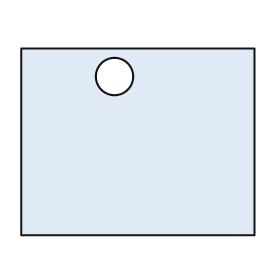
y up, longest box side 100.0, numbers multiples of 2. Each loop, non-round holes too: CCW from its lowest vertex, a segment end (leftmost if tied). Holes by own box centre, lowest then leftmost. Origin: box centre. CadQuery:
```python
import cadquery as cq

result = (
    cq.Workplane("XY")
    .moveTo(-50.0, -40.0)
    .lineTo(50.0, -40.0)
    .lineTo(50.0, 40.0)
    .lineTo(-50.0, 40.0)
    .close()
    .moveTo(-10.0, 28.0)
    .circle(8.0)
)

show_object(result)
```